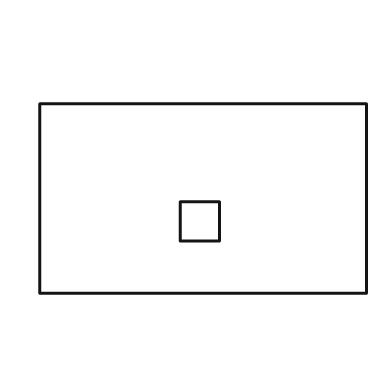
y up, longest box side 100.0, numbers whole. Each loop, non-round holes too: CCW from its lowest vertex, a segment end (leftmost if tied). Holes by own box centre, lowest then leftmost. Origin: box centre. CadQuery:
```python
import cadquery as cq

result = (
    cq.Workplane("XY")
    .moveTo(-50.0, -29.0)
    .lineTo(50.0, -29.0)
    .lineTo(50.0, 29.0)
    .lineTo(-50.0, 29.0)
    .close()
    .moveTo(-7.0, -13.0)
    .lineTo(5.0, -13.0)
    .lineTo(5.0, -1.0)
    .lineTo(-7.0, -1.0)
    .close()
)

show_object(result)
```